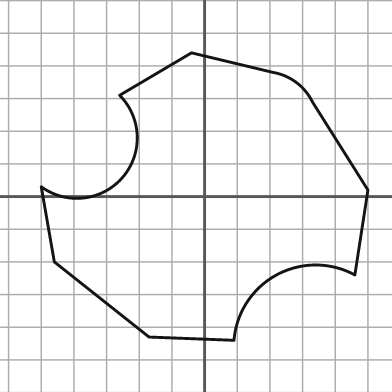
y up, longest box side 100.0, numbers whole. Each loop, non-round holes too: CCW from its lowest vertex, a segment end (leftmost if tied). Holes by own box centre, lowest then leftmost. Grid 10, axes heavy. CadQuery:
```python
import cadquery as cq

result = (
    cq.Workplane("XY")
    .moveTo(9.0, -44.0)
    .threePointArc((22.0, -24.0), (46.0, -24.0))
    .lineTo(50.0, 2.0)
    .lineTo(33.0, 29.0)
    .threePointArc((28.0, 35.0), (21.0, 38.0))
    .lineTo(-4.0, 44.0)
    .lineTo(-26.0, 31.0)
    .threePointArc((-25.0, 6.0), (-50.0, 3.0))
    .lineTo(-46.0, -20.0)
    .lineTo(-17.0, -43.0)
    .close()
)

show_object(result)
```